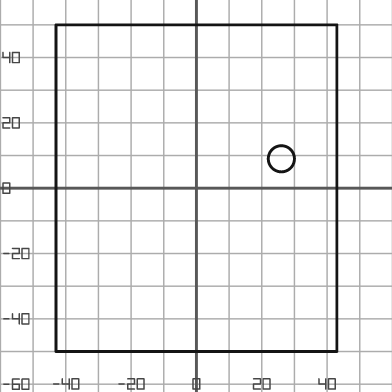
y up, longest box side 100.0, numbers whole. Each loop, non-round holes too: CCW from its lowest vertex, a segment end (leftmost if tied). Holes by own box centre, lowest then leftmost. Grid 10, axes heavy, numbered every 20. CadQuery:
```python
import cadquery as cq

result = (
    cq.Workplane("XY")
    .moveTo(-43.0, -50.0)
    .lineTo(43.0, -50.0)
    .lineTo(43.0, 50.0)
    .lineTo(-43.0, 50.0)
    .close()
    .moveTo(26.0, 9.0)
    .circle(4.0)
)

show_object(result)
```